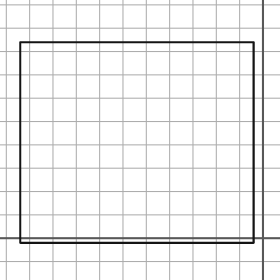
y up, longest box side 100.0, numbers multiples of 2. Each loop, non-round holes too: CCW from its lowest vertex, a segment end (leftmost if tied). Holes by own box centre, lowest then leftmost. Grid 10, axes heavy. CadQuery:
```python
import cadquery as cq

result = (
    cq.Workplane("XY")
    .moveTo(-104.0, -2.0)
    .lineTo(-4.0, -2.0)
    .lineTo(-4.0, 84.0)
    .lineTo(-104.0, 84.0)
    .close()
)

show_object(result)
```